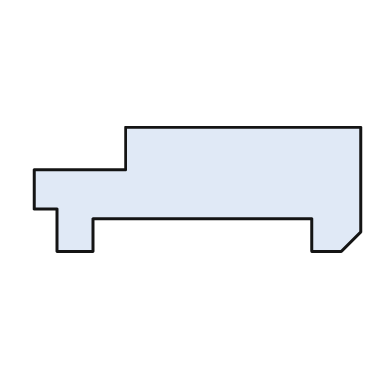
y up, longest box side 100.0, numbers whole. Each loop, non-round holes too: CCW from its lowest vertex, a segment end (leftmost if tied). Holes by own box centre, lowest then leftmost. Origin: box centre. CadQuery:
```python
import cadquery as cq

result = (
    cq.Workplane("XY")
    .moveTo(-43.0, -19.0)
    .lineTo(-32.0, -19.0)
    .lineTo(-32.0, -9.0)
    .lineTo(35.0, -9.0)
    .lineTo(35.0, -19.0)
    .lineTo(44.0, -19.0)
    .lineTo(50.0, -13.0)
    .lineTo(50.0, 19.0)
    .lineTo(-22.0, 19.0)
    .lineTo(-22.0, 6.0)
    .lineTo(-50.0, 6.0)
    .lineTo(-50.0, -6.0)
    .lineTo(-43.0, -6.0)
    .close()
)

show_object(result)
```